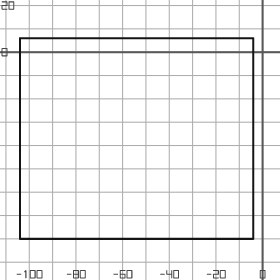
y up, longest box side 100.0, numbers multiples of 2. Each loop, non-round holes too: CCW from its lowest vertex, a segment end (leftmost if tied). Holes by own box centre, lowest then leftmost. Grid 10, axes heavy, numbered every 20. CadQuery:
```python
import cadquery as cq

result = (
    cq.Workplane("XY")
    .moveTo(-104.0, -80.0)
    .lineTo(-4.0, -80.0)
    .lineTo(-4.0, 6.0)
    .lineTo(-104.0, 6.0)
    .close()
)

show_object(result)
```